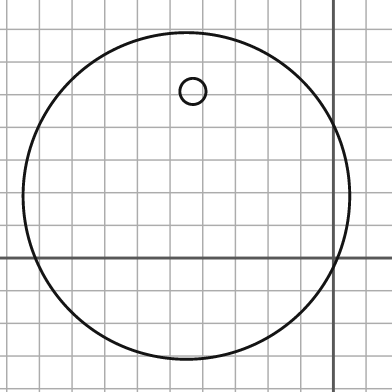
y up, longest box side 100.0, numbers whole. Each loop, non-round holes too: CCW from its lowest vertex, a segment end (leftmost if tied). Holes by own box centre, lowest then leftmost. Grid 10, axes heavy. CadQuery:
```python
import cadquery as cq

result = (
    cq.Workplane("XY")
    .moveTo(-45.0, 19.0)
    .circle(50.0)
    .moveTo(-43.0, 51.0)
    .circle(4.0)
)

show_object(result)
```